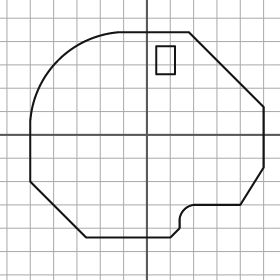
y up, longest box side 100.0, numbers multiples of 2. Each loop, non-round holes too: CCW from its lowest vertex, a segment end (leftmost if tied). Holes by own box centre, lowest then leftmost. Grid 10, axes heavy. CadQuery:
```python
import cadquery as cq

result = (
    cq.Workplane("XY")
    .moveTo(-26.0, -44.0)
    .lineTo(10.0, -44.0)
    .lineTo(14.0, -40.0)
    .lineTo(14.0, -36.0)
    .threePointArc((16.0, -32.0), (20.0, -30.0))
    .lineTo(40.0, -30.0)
    .lineTo(50.0, -14.0)
    .lineTo(50.0, 12.0)
    .lineTo(18.0, 44.0)
    .lineTo(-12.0, 44.0)
    .threePointArc((-38.0, 32.0), (-50.0, 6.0))
    .lineTo(-50.0, -20.0)
    .close()
    .moveTo(4.0, 26.0)
    .lineTo(12.0, 26.0)
    .lineTo(12.0, 38.0)
    .lineTo(4.0, 38.0)
    .close()
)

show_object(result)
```